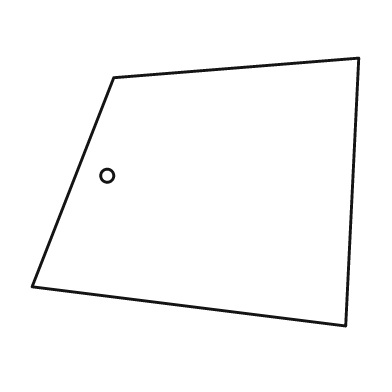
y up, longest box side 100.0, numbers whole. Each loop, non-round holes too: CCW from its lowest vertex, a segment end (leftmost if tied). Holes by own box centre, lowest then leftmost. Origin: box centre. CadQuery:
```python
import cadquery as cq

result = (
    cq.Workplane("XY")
    .moveTo(46.0, -41.0)
    .lineTo(50.0, 41.0)
    .lineTo(-25.0, 35.0)
    .lineTo(-50.0, -29.0)
    .close()
    .moveTo(-27.0, 5.0)
    .circle(2.0)
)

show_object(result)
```